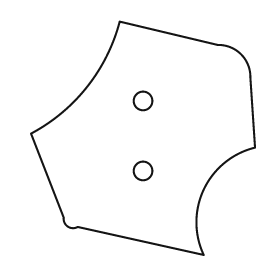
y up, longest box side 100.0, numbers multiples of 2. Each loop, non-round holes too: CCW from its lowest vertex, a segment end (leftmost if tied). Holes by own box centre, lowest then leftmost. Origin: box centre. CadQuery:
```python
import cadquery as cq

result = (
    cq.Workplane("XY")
    .moveTo(26.0, -50.0)
    .threePointArc((26.0, -22.0), (48.0, -4.0))
    .lineTo(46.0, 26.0)
    .threePointArc((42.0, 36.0), (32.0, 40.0))
    .lineTo(-10.0, 50.0)
    .threePointArc((-24.0, 22.0), (-48.0, 2.0))
    .lineTo(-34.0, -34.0)
    .threePointArc((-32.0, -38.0), (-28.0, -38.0))
    .close()
    .moveTo(0.0, -14.0)
    .circle(4.0)
    .moveTo(0.0, 16.0)
    .circle(4.0)
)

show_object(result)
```